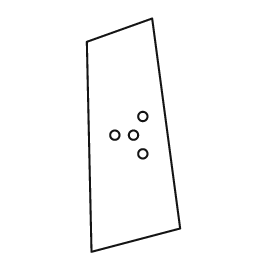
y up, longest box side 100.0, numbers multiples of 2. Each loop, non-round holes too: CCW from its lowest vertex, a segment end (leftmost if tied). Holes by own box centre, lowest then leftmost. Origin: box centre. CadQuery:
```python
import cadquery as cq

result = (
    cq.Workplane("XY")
    .moveTo(-18.0, -50.0)
    .lineTo(20.0, -40.0)
    .lineTo(8.0, 50.0)
    .lineTo(-20.0, 40.0)
    .close()
    .moveTo(4.0, -8.0)
    .circle(2.0)
    .moveTo(-8.0, 0.0)
    .circle(2.0)
    .moveTo(0.0, 0.0)
    .circle(2.0)
    .moveTo(4.0, 8.0)
    .circle(2.0)
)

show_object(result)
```